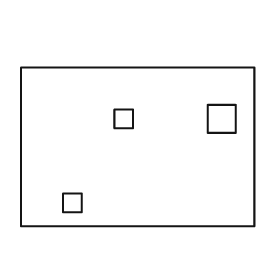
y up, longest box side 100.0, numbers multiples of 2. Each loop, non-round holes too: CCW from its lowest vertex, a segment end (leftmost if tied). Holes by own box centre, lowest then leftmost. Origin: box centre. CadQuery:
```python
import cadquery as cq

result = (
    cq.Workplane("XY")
    .moveTo(-50.0, -34.0)
    .lineTo(50.0, -34.0)
    .lineTo(50.0, 34.0)
    .lineTo(-50.0, 34.0)
    .close()
    .moveTo(-32.0, -28.0)
    .lineTo(-24.0, -28.0)
    .lineTo(-24.0, -20.0)
    .lineTo(-32.0, -20.0)
    .close()
    .moveTo(-10.0, 8.0)
    .lineTo(-2.0, 8.0)
    .lineTo(-2.0, 16.0)
    .lineTo(-10.0, 16.0)
    .close()
    .moveTo(30.0, 6.0)
    .lineTo(42.0, 6.0)
    .lineTo(42.0, 18.0)
    .lineTo(30.0, 18.0)
    .close()
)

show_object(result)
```